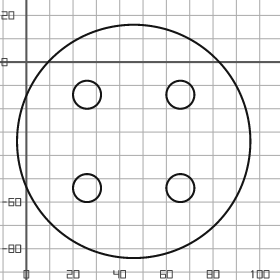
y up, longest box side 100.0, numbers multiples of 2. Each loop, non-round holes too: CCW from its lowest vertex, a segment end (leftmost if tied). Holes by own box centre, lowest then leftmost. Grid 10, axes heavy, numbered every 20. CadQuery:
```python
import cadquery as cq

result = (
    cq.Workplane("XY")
    .moveTo(46.0, -34.0)
    .circle(50.0)
    .moveTo(26.0, -54.0)
    .circle(6.0)
    .moveTo(66.0, -54.0)
    .circle(6.0)
    .moveTo(26.0, -14.0)
    .circle(6.0)
    .moveTo(66.0, -14.0)
    .circle(6.0)
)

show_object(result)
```